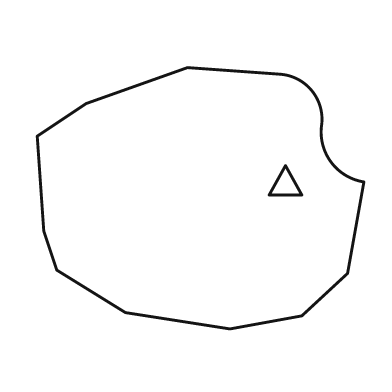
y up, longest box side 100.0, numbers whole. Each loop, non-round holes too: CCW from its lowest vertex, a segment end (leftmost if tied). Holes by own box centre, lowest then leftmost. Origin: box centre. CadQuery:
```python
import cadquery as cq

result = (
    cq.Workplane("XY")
    .moveTo(9.0, -40.0)
    .lineTo(31.0, -36.0)
    .lineTo(45.0, -23.0)
    .lineTo(50.0, 5.0)
    .threePointArc((40.0, 11.0), (37.0, 22.0))
    .threePointArc((34.0, 33.0), (24.0, 38.0))
    .lineTo(-4.0, 40.0)
    .lineTo(-35.0, 29.0)
    .lineTo(-50.0, 19.0)
    .lineTo(-48.0, -10.0)
    .lineTo(-44.0, -22.0)
    .lineTo(-23.0, -35.0)
    .close()
    .moveTo(21.0, 1.0)
    .lineTo(31.0, 1.0)
    .lineTo(26.0, 10.0)
    .close()
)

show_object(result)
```